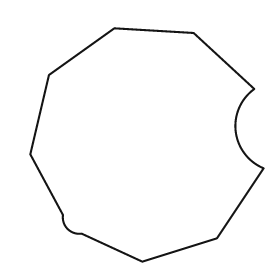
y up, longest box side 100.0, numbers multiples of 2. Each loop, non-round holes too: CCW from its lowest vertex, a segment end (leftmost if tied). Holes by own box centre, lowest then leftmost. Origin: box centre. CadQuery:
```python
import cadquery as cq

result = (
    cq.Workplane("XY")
    .moveTo(-2.0, -50.0)
    .lineTo(30.0, -40.0)
    .lineTo(50.0, -10.0)
    .threePointArc((38.0, 6.0), (46.0, 24.0))
    .lineTo(20.0, 48.0)
    .lineTo(-14.0, 50.0)
    .lineTo(-42.0, 30.0)
    .lineTo(-50.0, -4.0)
    .lineTo(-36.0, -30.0)
    .threePointArc((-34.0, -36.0), (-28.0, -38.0))
    .close()
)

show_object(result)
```